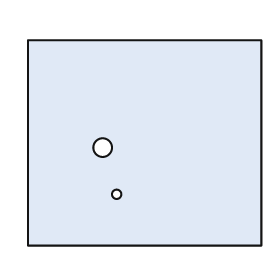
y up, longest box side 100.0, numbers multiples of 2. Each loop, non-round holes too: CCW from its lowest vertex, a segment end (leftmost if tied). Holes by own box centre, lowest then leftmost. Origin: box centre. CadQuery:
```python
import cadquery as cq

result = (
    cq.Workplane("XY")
    .moveTo(-50.0, -44.0)
    .lineTo(50.0, -44.0)
    .lineTo(50.0, 44.0)
    .lineTo(-50.0, 44.0)
    .close()
    .moveTo(-12.0, -22.0)
    .circle(2.0)
    .moveTo(-18.0, -2.0)
    .circle(4.0)
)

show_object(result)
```